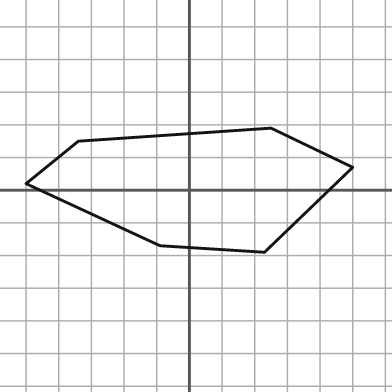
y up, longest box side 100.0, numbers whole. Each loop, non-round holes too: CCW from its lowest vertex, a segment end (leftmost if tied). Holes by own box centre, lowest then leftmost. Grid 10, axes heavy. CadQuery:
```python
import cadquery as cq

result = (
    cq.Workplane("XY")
    .moveTo(23.0, -19.0)
    .lineTo(50.0, 7.0)
    .lineTo(25.0, 19.0)
    .lineTo(-34.0, 15.0)
    .lineTo(-50.0, 2.0)
    .lineTo(-9.0, -17.0)
    .close()
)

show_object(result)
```